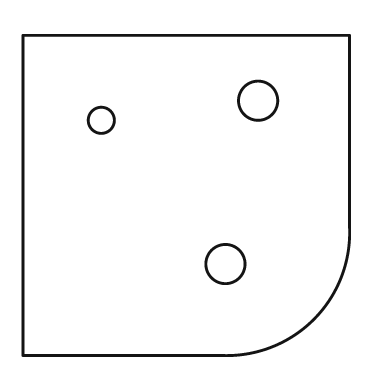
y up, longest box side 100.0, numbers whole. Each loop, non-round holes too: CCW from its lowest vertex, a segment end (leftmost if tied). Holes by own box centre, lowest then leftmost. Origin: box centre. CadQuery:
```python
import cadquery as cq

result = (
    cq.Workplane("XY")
    .moveTo(-50.0, -49.0)
    .lineTo(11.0, -49.0)
    .threePointArc((39.0, -38.0), (50.0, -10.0))
    .lineTo(50.0, 49.0)
    .lineTo(-50.0, 49.0)
    .close()
    .moveTo(12.0, -21.0)
    .circle(6.0)
    .moveTo(-26.0, 23.0)
    .circle(4.0)
    .moveTo(22.0, 29.0)
    .circle(6.0)
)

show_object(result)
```